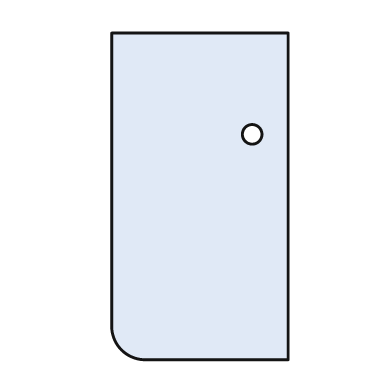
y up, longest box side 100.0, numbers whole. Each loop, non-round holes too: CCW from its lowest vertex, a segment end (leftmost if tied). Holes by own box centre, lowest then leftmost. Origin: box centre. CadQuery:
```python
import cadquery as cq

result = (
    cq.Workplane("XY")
    .moveTo(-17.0, -50.0)
    .lineTo(27.0, -50.0)
    .lineTo(27.0, 50.0)
    .lineTo(-27.0, 50.0)
    .lineTo(-27.0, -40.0)
    .threePointArc((-24.0, -47.0), (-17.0, -50.0))
    .close()
    .moveTo(16.0, 19.0)
    .circle(3.0)
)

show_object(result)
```